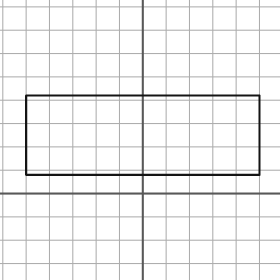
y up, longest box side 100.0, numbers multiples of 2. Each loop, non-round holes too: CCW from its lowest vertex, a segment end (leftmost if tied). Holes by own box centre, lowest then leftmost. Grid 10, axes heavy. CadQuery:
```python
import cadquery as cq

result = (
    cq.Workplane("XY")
    .moveTo(-50.0, 8.0)
    .lineTo(50.0, 8.0)
    .lineTo(50.0, 42.0)
    .lineTo(-50.0, 42.0)
    .close()
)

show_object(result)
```